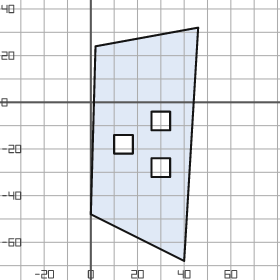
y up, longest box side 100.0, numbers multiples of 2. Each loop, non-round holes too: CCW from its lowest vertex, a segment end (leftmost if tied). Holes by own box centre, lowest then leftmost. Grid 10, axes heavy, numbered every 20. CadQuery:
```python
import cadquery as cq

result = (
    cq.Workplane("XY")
    .moveTo(40.0, -68.0)
    .lineTo(46.0, 32.0)
    .lineTo(2.0, 24.0)
    .lineTo(0.0, -48.0)
    .close()
    .moveTo(26.0, -32.0)
    .lineTo(34.0, -32.0)
    .lineTo(34.0, -24.0)
    .lineTo(26.0, -24.0)
    .close()
    .moveTo(10.0, -22.0)
    .lineTo(18.0, -22.0)
    .lineTo(18.0, -14.0)
    .lineTo(10.0, -14.0)
    .close()
    .moveTo(26.0, -12.0)
    .lineTo(34.0, -12.0)
    .lineTo(34.0, -4.0)
    .lineTo(26.0, -4.0)
    .close()
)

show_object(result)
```